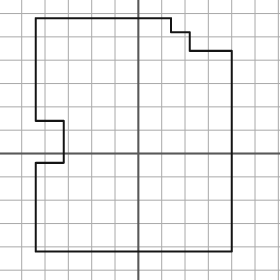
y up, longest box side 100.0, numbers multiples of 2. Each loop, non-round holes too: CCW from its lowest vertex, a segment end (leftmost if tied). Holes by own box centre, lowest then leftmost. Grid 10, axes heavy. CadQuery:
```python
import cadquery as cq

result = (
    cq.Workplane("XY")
    .moveTo(-44.0, -42.0)
    .lineTo(40.0, -42.0)
    .lineTo(40.0, 44.0)
    .lineTo(22.0, 44.0)
    .lineTo(22.0, 52.0)
    .lineTo(14.0, 52.0)
    .lineTo(14.0, 58.0)
    .lineTo(-44.0, 58.0)
    .lineTo(-44.0, 14.0)
    .lineTo(-32.0, 14.0)
    .lineTo(-32.0, -4.0)
    .lineTo(-44.0, -4.0)
    .close()
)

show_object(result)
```